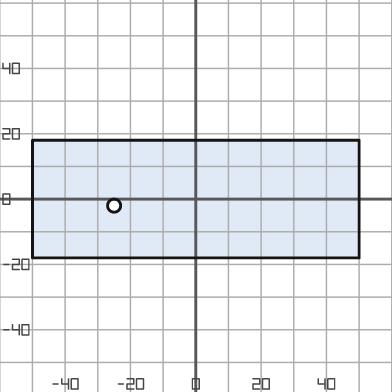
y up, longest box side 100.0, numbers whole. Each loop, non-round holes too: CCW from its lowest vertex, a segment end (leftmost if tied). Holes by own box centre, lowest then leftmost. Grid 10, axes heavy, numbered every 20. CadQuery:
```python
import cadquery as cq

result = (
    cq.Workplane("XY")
    .moveTo(-50.0, -18.0)
    .lineTo(50.0, -18.0)
    .lineTo(50.0, 18.0)
    .lineTo(-50.0, 18.0)
    .close()
    .moveTo(-25.0, -2.0)
    .circle(2.0)
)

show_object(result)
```